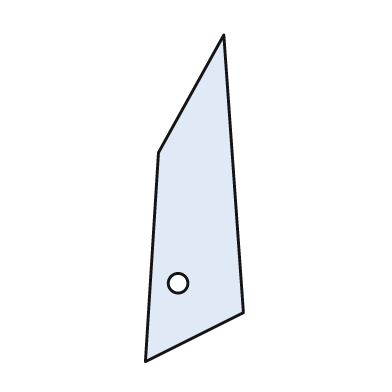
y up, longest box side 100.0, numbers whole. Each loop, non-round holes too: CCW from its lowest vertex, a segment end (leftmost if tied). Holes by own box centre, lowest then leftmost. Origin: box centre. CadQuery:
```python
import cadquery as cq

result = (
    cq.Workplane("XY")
    .moveTo(-15.0, -50.0)
    .lineTo(15.0, -35.0)
    .lineTo(9.0, 50.0)
    .lineTo(-11.0, 14.0)
    .close()
    .moveTo(-5.0, -26.0)
    .circle(3.0)
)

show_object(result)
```